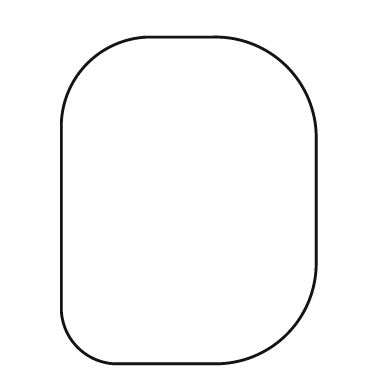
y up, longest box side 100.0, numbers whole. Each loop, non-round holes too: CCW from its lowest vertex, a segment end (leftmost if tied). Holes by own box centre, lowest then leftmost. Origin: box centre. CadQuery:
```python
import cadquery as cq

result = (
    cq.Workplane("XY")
    .moveTo(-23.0, -50.0)
    .lineTo(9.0, -50.0)
    .threePointArc((30.0, -41.0), (39.0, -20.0))
    .lineTo(39.0, 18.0)
    .threePointArc((30.0, 41.0), (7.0, 50.0))
    .lineTo(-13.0, 50.0)
    .threePointArc((-31.0, 42.0), (-39.0, 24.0))
    .lineTo(-39.0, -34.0)
    .threePointArc((-34.0, -45.0), (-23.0, -50.0))
    .close()
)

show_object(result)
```